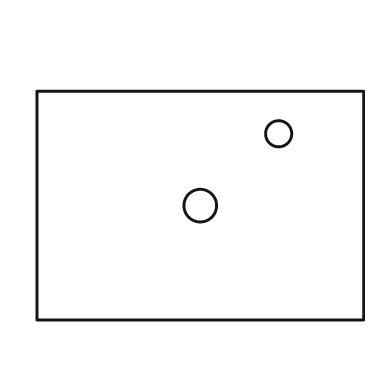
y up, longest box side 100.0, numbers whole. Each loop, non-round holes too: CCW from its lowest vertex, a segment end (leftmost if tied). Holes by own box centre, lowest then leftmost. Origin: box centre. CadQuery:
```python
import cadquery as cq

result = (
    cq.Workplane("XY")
    .moveTo(-50.0, -35.0)
    .lineTo(50.0, -35.0)
    .lineTo(50.0, 35.0)
    .lineTo(-50.0, 35.0)
    .close()
    .moveTo(0.0, 0.0)
    .circle(5.0)
    .moveTo(24.0, 22.0)
    .circle(4.0)
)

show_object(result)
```